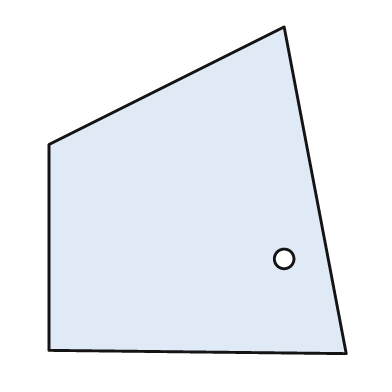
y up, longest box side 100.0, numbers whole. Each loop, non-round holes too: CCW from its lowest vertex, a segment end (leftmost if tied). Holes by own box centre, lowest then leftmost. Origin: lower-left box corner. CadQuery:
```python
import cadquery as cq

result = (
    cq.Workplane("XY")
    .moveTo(91.0, 0.0)
    .lineTo(72.0, 100.0)
    .lineTo(0.0, 64.0)
    .lineTo(0.0, 1.0)
    .close()
    .moveTo(72.0, 29.0)
    .circle(3.0)
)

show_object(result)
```